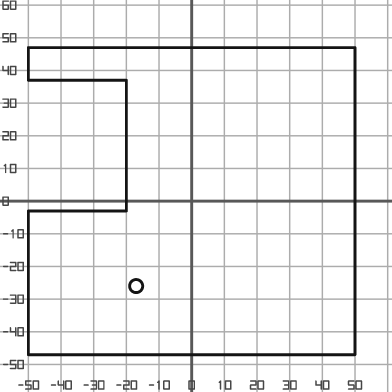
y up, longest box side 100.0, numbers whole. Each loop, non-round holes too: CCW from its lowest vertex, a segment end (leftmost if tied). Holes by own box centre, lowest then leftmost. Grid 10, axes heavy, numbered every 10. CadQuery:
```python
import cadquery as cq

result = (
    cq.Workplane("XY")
    .moveTo(-50.0, -47.0)
    .lineTo(50.0, -47.0)
    .lineTo(50.0, 47.0)
    .lineTo(-50.0, 47.0)
    .lineTo(-50.0, 37.0)
    .lineTo(-20.0, 37.0)
    .lineTo(-20.0, -3.0)
    .lineTo(-50.0, -3.0)
    .close()
    .moveTo(-17.0, -26.0)
    .circle(2.0)
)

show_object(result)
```